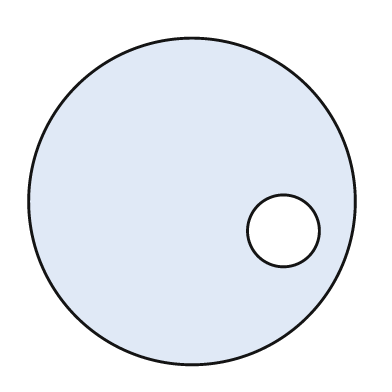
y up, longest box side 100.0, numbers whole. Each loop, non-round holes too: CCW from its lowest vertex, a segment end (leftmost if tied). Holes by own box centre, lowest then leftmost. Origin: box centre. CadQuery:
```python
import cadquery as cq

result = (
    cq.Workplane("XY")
    .moveTo(0.0, 0.0)
    .circle(50.0)
    .moveTo(28.0, -9.0)
    .circle(11.0)
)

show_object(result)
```